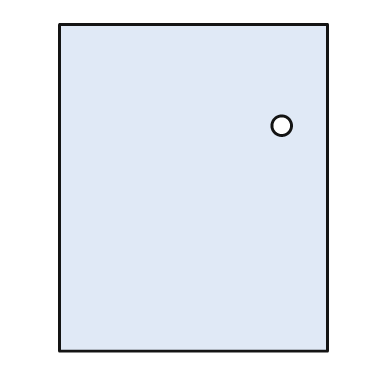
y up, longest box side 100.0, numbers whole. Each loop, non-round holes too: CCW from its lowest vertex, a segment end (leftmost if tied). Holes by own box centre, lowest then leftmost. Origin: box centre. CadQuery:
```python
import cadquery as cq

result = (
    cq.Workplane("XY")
    .moveTo(-41.0, -50.0)
    .lineTo(41.0, -50.0)
    .lineTo(41.0, 50.0)
    .lineTo(-41.0, 50.0)
    .close()
    .moveTo(27.0, 19.0)
    .circle(3.0)
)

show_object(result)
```